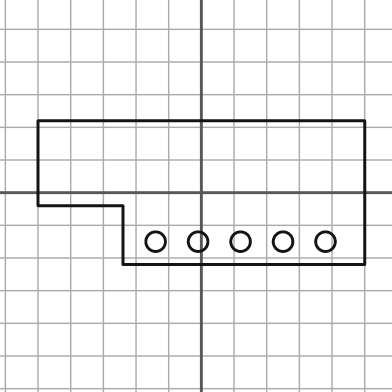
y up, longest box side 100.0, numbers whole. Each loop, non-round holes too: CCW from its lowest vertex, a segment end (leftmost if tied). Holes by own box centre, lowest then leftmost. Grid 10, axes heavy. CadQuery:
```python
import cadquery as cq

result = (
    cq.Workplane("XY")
    .moveTo(-24.0, -22.0)
    .lineTo(50.0, -22.0)
    .lineTo(50.0, 22.0)
    .lineTo(-50.0, 22.0)
    .lineTo(-50.0, -4.0)
    .lineTo(-24.0, -4.0)
    .close()
    .moveTo(-14.0, -15.0)
    .circle(3.0)
    .moveTo(-1.0, -15.0)
    .circle(3.0)
    .moveTo(12.0, -15.0)
    .circle(3.0)
    .moveTo(25.0, -15.0)
    .circle(3.0)
    .moveTo(38.0, -15.0)
    .circle(3.0)
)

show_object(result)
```